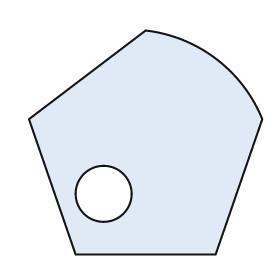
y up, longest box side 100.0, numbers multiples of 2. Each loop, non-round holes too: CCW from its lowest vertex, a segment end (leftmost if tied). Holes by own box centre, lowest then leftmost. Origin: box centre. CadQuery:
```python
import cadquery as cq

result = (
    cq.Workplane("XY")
    .moveTo(-30.0, -48.0)
    .lineTo(30.0, -48.0)
    .lineTo(50.0, 10.0)
    .threePointArc((30.0, 36.0), (0.0, 48.0))
    .lineTo(-50.0, 10.0)
    .close()
    .moveTo(-18.0, -22.0)
    .circle(12.0)
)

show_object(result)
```